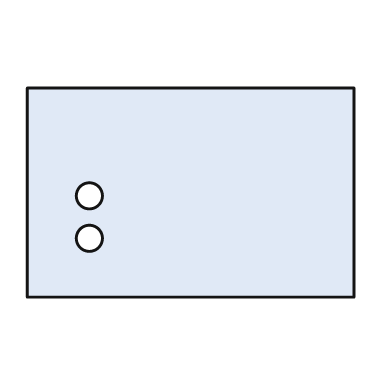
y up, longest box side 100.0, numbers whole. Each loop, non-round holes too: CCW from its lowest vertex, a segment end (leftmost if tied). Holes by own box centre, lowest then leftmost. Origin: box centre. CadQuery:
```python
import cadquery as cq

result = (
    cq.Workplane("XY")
    .moveTo(-50.0, -32.0)
    .lineTo(50.0, -32.0)
    .lineTo(50.0, 32.0)
    .lineTo(-50.0, 32.0)
    .close()
    .moveTo(-31.0, -14.0)
    .circle(4.0)
    .moveTo(-31.0, -1.0)
    .circle(4.0)
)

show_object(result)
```